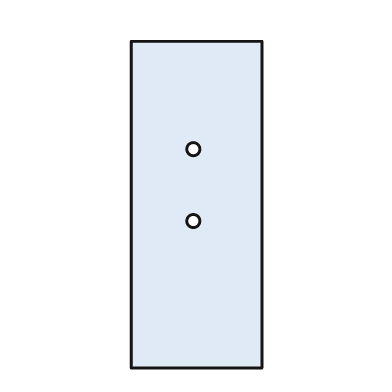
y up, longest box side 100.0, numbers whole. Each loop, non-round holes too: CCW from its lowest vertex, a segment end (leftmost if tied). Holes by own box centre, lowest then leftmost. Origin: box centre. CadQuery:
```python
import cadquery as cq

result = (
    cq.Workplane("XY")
    .moveTo(-20.0, -50.0)
    .lineTo(20.0, -50.0)
    .lineTo(20.0, 50.0)
    .lineTo(-20.0, 50.0)
    .close()
    .moveTo(-1.0, -5.0)
    .circle(2.0)
    .moveTo(-1.0, 17.0)
    .circle(2.0)
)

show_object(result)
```